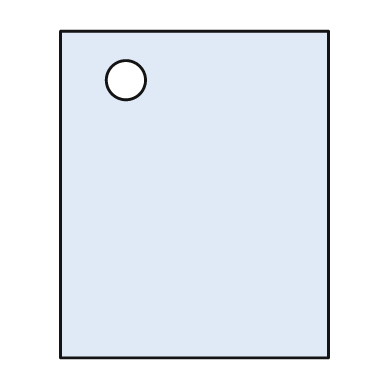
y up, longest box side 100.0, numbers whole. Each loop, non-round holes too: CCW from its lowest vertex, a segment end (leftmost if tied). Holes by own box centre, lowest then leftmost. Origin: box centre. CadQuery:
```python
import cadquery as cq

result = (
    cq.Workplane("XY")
    .moveTo(-41.0, -50.0)
    .lineTo(41.0, -50.0)
    .lineTo(41.0, 50.0)
    .lineTo(-41.0, 50.0)
    .close()
    .moveTo(-21.0, 35.0)
    .circle(6.0)
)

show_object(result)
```